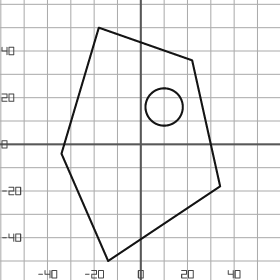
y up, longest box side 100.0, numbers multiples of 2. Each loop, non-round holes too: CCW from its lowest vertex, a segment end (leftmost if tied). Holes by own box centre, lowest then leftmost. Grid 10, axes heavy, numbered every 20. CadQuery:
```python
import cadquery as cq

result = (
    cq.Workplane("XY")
    .moveTo(-14.0, -50.0)
    .lineTo(34.0, -18.0)
    .lineTo(22.0, 36.0)
    .lineTo(-18.0, 50.0)
    .lineTo(-34.0, -4.0)
    .close()
    .moveTo(10.0, 16.0)
    .circle(8.0)
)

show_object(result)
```